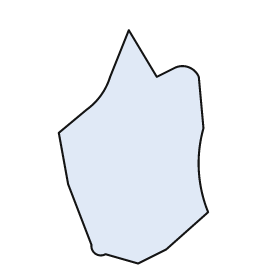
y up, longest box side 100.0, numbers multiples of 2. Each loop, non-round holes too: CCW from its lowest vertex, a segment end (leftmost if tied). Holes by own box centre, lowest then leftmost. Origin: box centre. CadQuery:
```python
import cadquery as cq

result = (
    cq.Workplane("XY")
    .moveTo(2.0, -50.0)
    .lineTo(14.0, -44.0)
    .lineTo(32.0, -28.0)
    .threePointArc((28.0, -10.0), (30.0, 8.0))
    .lineTo(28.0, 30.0)
    .threePointArc((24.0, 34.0), (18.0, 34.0))
    .lineTo(10.0, 30.0)
    .lineTo(-2.0, 50.0)
    .lineTo(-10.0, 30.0)
    .threePointArc((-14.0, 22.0), (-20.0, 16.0))
    .lineTo(-32.0, 6.0)
    .lineTo(-28.0, -16.0)
    .lineTo(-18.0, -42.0)
    .threePointArc((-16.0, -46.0), (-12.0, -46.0))
    .close()
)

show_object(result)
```